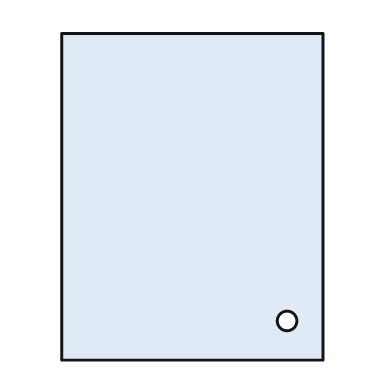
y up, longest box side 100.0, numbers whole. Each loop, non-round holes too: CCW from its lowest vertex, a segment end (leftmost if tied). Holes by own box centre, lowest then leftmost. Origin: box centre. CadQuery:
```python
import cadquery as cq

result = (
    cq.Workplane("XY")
    .moveTo(-40.0, -50.0)
    .lineTo(40.0, -50.0)
    .lineTo(40.0, 50.0)
    .lineTo(-40.0, 50.0)
    .close()
    .moveTo(29.0, -38.0)
    .circle(3.0)
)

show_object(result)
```